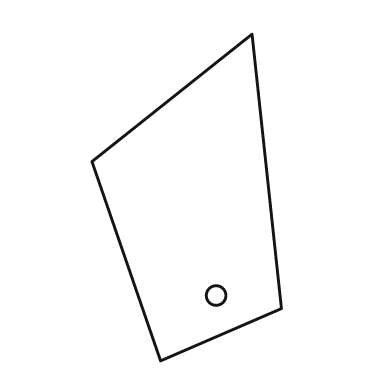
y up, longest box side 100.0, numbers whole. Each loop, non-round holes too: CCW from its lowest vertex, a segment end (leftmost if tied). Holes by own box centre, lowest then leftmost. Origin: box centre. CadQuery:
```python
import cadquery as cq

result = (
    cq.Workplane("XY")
    .moveTo(-8.0, -50.0)
    .lineTo(29.0, -34.0)
    .lineTo(20.0, 50.0)
    .lineTo(-29.0, 11.0)
    .close()
    .moveTo(9.0, -30.0)
    .circle(3.0)
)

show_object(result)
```